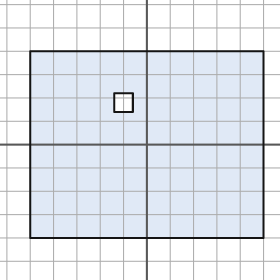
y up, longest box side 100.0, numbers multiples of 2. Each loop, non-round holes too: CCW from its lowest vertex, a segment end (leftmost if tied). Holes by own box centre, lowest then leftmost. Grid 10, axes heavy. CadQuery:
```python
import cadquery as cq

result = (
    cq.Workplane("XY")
    .moveTo(-50.0, -40.0)
    .lineTo(50.0, -40.0)
    .lineTo(50.0, 40.0)
    .lineTo(-50.0, 40.0)
    .close()
    .moveTo(-14.0, 14.0)
    .lineTo(-6.0, 14.0)
    .lineTo(-6.0, 22.0)
    .lineTo(-14.0, 22.0)
    .close()
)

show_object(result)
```